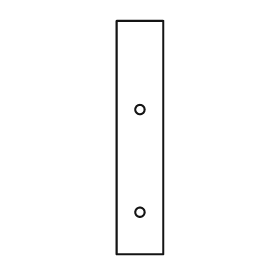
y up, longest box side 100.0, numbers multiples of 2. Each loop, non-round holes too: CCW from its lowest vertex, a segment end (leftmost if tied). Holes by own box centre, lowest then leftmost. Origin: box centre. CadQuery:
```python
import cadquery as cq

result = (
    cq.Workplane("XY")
    .moveTo(-10.0, -50.0)
    .lineTo(10.0, -50.0)
    .lineTo(10.0, 50.0)
    .lineTo(-10.0, 50.0)
    .close()
    .moveTo(0.0, -32.0)
    .circle(2.0)
    .moveTo(0.0, 12.0)
    .circle(2.0)
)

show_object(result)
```